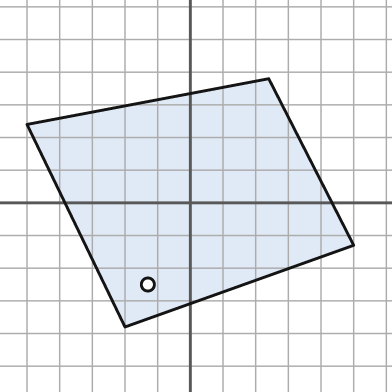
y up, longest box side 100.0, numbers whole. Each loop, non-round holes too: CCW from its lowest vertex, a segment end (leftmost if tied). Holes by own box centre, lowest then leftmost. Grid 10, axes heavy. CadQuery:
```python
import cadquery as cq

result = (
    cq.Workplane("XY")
    .moveTo(-20.0, -38.0)
    .lineTo(50.0, -13.0)
    .lineTo(24.0, 38.0)
    .lineTo(-50.0, 24.0)
    .close()
    .moveTo(-13.0, -25.0)
    .circle(2.0)
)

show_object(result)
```